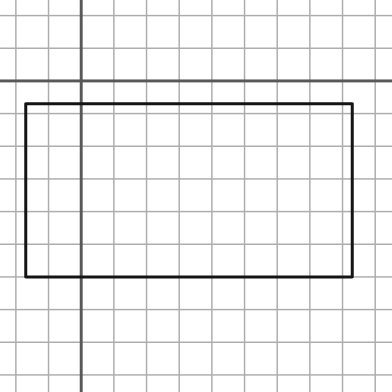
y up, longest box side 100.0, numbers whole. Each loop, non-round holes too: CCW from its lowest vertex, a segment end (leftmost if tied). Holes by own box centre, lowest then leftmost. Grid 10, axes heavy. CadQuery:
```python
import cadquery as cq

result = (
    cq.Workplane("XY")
    .moveTo(-17.0, -60.0)
    .lineTo(83.0, -60.0)
    .lineTo(83.0, -7.0)
    .lineTo(-17.0, -7.0)
    .close()
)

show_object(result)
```